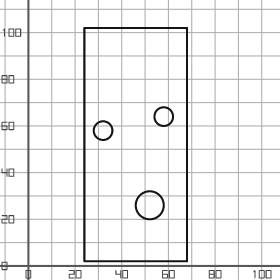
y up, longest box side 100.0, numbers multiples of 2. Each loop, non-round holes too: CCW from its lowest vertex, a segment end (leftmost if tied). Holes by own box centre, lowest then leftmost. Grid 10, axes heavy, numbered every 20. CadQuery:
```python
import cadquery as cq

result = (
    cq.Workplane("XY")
    .moveTo(24.0, 2.0)
    .lineTo(68.0, 2.0)
    .lineTo(68.0, 102.0)
    .lineTo(24.0, 102.0)
    .close()
    .moveTo(52.0, 26.0)
    .circle(6.0)
    .moveTo(32.0, 58.0)
    .circle(4.0)
    .moveTo(58.0, 64.0)
    .circle(4.0)
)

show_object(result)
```